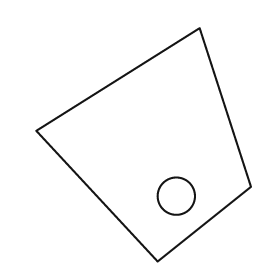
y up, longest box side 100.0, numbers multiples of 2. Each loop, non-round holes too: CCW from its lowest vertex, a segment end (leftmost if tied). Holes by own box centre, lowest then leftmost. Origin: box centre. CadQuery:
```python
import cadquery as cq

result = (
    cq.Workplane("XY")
    .moveTo(6.0, -50.0)
    .lineTo(46.0, -18.0)
    .lineTo(24.0, 50.0)
    .lineTo(-46.0, 6.0)
    .close()
    .moveTo(14.0, -22.0)
    .circle(8.0)
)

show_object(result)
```